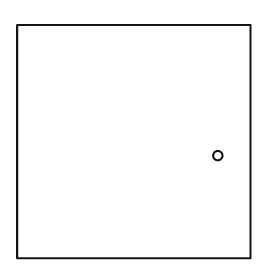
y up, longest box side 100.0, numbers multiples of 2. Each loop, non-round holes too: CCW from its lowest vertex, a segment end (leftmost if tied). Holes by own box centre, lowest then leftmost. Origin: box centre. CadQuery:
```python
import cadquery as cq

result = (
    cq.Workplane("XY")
    .moveTo(-50.0, -50.0)
    .lineTo(50.0, -50.0)
    .lineTo(50.0, 50.0)
    .lineTo(-50.0, 50.0)
    .close()
    .moveTo(36.0, -6.0)
    .circle(2.0)
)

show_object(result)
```